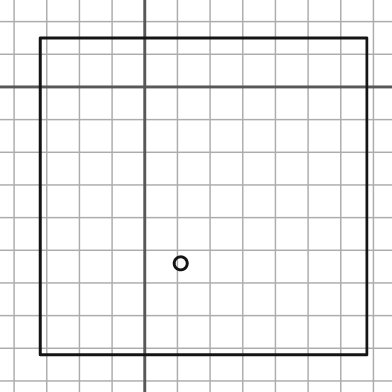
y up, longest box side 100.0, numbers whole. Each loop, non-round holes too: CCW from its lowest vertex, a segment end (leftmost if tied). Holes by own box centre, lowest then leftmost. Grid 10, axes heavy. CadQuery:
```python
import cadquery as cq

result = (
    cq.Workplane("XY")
    .moveTo(-32.0, -82.0)
    .lineTo(68.0, -82.0)
    .lineTo(68.0, 15.0)
    .lineTo(-32.0, 15.0)
    .close()
    .moveTo(11.0, -54.0)
    .circle(2.0)
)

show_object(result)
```